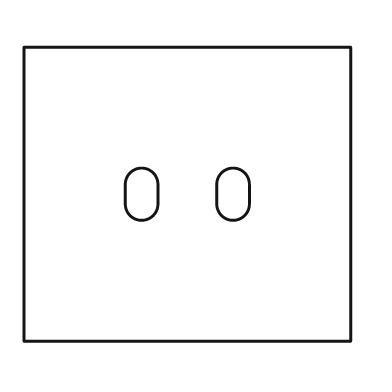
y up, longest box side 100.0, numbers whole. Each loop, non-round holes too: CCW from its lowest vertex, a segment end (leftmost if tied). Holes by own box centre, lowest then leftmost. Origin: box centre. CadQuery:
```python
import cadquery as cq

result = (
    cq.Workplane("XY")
    .moveTo(-50.0, -45.0)
    .lineTo(50.0, -45.0)
    .lineTo(50.0, 45.0)
    .lineTo(-50.0, 45.0)
    .close()
    .moveTo(-19.0, -3.0)
    .threePointArc((-14.0, -8.0), (-9.0, -3.0))
    .lineTo(-9.0, 3.0)
    .threePointArc((-14.0, 8.0), (-19.0, 3.0))
    .close()
    .moveTo(9.0, -3.0)
    .threePointArc((14.0, -8.0), (19.0, -3.0))
    .lineTo(19.0, 3.0)
    .threePointArc((14.0, 8.0), (9.0, 3.0))
    .close()
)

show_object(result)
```